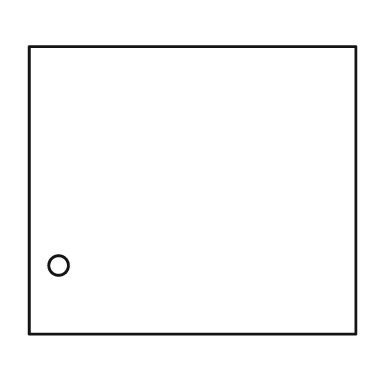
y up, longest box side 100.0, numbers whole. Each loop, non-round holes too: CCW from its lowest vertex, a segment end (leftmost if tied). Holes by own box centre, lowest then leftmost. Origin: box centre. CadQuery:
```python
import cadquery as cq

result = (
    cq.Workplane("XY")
    .moveTo(-50.0, -44.0)
    .lineTo(50.0, -44.0)
    .lineTo(50.0, 44.0)
    .lineTo(-50.0, 44.0)
    .close()
    .moveTo(-41.0, -23.0)
    .circle(3.0)
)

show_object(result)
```